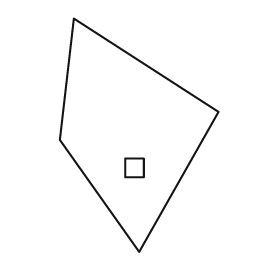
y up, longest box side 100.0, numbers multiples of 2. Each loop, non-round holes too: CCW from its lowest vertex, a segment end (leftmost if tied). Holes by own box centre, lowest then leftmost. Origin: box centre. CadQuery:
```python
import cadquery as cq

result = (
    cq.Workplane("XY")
    .moveTo(0.0, -50.0)
    .lineTo(34.0, 10.0)
    .lineTo(-28.0, 50.0)
    .lineTo(-34.0, -2.0)
    .close()
    .moveTo(-6.0, -18.0)
    .lineTo(2.0, -18.0)
    .lineTo(2.0, -10.0)
    .lineTo(-6.0, -10.0)
    .close()
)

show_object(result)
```